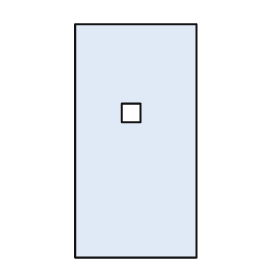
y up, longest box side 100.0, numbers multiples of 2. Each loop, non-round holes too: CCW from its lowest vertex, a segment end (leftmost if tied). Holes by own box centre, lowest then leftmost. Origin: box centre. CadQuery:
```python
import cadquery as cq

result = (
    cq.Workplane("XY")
    .moveTo(-26.0, -50.0)
    .lineTo(26.0, -50.0)
    .lineTo(26.0, 50.0)
    .lineTo(-26.0, 50.0)
    .close()
    .moveTo(-6.0, 8.0)
    .lineTo(2.0, 8.0)
    .lineTo(2.0, 16.0)
    .lineTo(-6.0, 16.0)
    .close()
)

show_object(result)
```